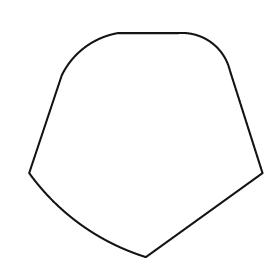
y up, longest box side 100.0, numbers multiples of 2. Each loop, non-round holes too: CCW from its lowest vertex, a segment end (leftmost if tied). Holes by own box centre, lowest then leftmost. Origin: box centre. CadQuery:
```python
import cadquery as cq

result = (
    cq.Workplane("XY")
    .moveTo(0.0, -48.0)
    .lineTo(50.0, -12.0)
    .lineTo(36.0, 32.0)
    .threePointArc((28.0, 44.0), (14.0, 48.0))
    .lineTo(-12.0, 48.0)
    .threePointArc((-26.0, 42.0), (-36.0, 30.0))
    .lineTo(-50.0, -12.0)
    .threePointArc((-28.0, -34.0), (0.0, -48.0))
    .close()
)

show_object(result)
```